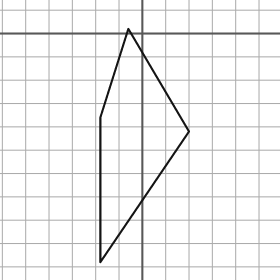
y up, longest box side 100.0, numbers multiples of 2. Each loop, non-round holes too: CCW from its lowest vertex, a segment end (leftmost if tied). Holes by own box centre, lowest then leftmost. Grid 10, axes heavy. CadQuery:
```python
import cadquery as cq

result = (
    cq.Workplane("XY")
    .moveTo(-18.0, -98.0)
    .lineTo(20.0, -42.0)
    .lineTo(-6.0, 2.0)
    .lineTo(-18.0, -36.0)
    .close()
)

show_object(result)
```